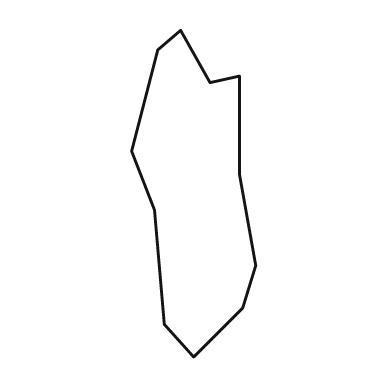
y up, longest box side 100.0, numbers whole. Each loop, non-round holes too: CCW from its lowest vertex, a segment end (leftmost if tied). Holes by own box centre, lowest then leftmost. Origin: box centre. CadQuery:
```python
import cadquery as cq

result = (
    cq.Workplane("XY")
    .moveTo(0.0, -50.0)
    .lineTo(15.0, -35.0)
    .lineTo(19.0, -22.0)
    .lineTo(14.0, 6.0)
    .lineTo(14.0, 36.0)
    .lineTo(5.0, 34.0)
    .lineTo(-4.0, 50.0)
    .lineTo(-11.0, 44.0)
    .lineTo(-19.0, 13.0)
    .lineTo(-12.0, -5.0)
    .lineTo(-9.0, -40.0)
    .close()
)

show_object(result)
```